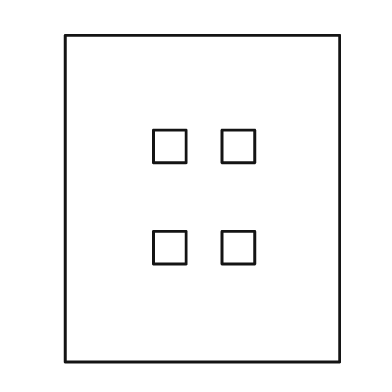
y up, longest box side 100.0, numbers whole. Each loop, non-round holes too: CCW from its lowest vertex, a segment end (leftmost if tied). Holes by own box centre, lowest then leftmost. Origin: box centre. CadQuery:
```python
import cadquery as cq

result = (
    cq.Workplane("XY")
    .moveTo(-42.0, -50.0)
    .lineTo(42.0, -50.0)
    .lineTo(42.0, 50.0)
    .lineTo(-42.0, 50.0)
    .close()
    .moveTo(-15.0, -20.0)
    .lineTo(-5.0, -20.0)
    .lineTo(-5.0, -10.0)
    .lineTo(-15.0, -10.0)
    .close()
    .moveTo(6.0, -20.0)
    .lineTo(16.0, -20.0)
    .lineTo(16.0, -10.0)
    .lineTo(6.0, -10.0)
    .close()
    .moveTo(-15.0, 11.0)
    .lineTo(-5.0, 11.0)
    .lineTo(-5.0, 21.0)
    .lineTo(-15.0, 21.0)
    .close()
    .moveTo(6.0, 11.0)
    .lineTo(16.0, 11.0)
    .lineTo(16.0, 21.0)
    .lineTo(6.0, 21.0)
    .close()
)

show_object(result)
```